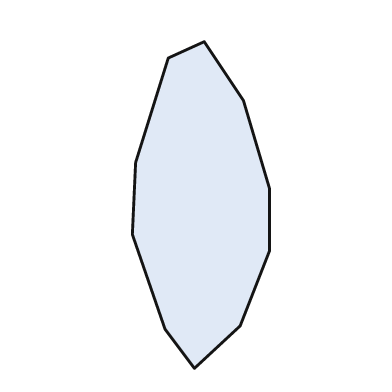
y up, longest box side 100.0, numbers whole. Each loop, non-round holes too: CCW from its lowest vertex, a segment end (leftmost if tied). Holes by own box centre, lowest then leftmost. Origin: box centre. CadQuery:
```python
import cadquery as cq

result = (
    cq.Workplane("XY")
    .moveTo(-2.0, -50.0)
    .lineTo(12.0, -37.0)
    .lineTo(21.0, -14.0)
    .lineTo(21.0, 5.0)
    .lineTo(13.0, 32.0)
    .lineTo(1.0, 50.0)
    .lineTo(-10.0, 45.0)
    .lineTo(-20.0, 13.0)
    .lineTo(-21.0, -9.0)
    .lineTo(-11.0, -38.0)
    .close()
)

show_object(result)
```